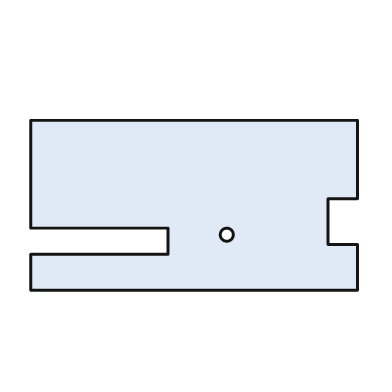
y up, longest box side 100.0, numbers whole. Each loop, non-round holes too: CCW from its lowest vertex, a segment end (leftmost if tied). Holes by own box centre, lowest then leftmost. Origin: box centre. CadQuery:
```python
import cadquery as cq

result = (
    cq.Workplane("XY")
    .moveTo(-50.0, -26.0)
    .lineTo(50.0, -26.0)
    .lineTo(50.0, -12.0)
    .lineTo(41.0, -12.0)
    .lineTo(41.0, 2.0)
    .lineTo(50.0, 2.0)
    .lineTo(50.0, 26.0)
    .lineTo(-50.0, 26.0)
    .lineTo(-50.0, -7.0)
    .lineTo(-8.0, -7.0)
    .lineTo(-8.0, -15.0)
    .lineTo(-50.0, -15.0)
    .close()
    .moveTo(10.0, -9.0)
    .circle(2.0)
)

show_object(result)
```